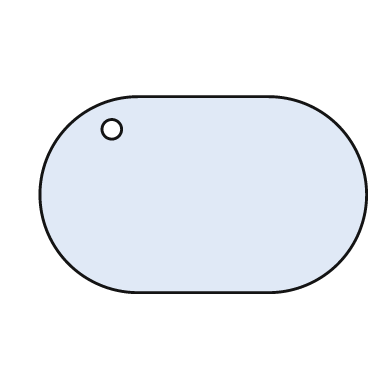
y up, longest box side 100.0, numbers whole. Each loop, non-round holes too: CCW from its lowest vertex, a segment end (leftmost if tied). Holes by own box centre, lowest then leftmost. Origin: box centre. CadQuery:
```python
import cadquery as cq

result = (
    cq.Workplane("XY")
    .moveTo(-20.0, -30.0)
    .lineTo(20.0, -30.0)
    .threePointArc((50.0, 0.0), (20.0, 30.0))
    .lineTo(-20.0, 30.0)
    .threePointArc((-50.0, 0.0), (-20.0, -30.0))
    .close()
    .moveTo(-28.0, 20.0)
    .circle(3.0)
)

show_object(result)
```